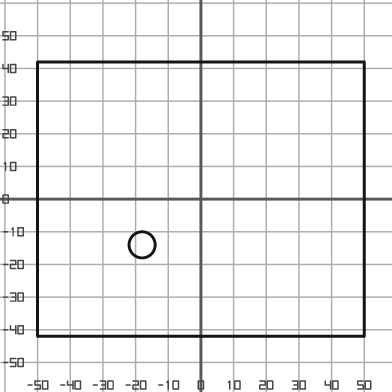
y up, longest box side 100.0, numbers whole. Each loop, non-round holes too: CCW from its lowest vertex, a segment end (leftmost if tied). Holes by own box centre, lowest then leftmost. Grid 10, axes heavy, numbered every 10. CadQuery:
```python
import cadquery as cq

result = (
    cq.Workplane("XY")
    .moveTo(-50.0, -42.0)
    .lineTo(50.0, -42.0)
    .lineTo(50.0, 42.0)
    .lineTo(-50.0, 42.0)
    .close()
    .moveTo(-18.0, -14.0)
    .circle(4.0)
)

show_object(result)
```